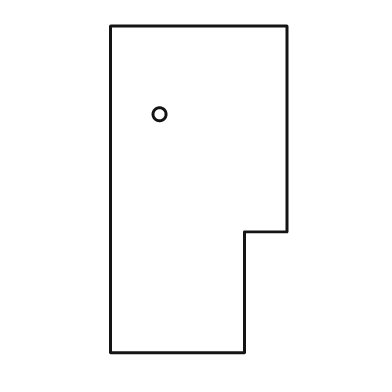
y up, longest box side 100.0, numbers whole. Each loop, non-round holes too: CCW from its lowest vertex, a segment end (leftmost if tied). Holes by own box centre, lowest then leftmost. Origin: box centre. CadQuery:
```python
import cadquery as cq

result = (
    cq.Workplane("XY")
    .moveTo(-27.0, -50.0)
    .lineTo(14.0, -50.0)
    .lineTo(14.0, -13.0)
    .lineTo(27.0, -13.0)
    .lineTo(27.0, 50.0)
    .lineTo(-27.0, 50.0)
    .close()
    .moveTo(-12.0, 23.0)
    .circle(2.0)
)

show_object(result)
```